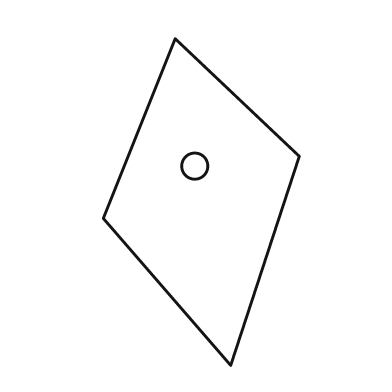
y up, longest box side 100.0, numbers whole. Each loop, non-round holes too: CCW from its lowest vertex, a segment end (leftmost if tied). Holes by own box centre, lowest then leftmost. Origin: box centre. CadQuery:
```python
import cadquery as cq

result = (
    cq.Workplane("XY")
    .moveTo(9.0, -50.0)
    .lineTo(30.0, 14.0)
    .lineTo(-8.0, 50.0)
    .lineTo(-30.0, -5.0)
    .close()
    .moveTo(-2.0, 11.0)
    .circle(4.0)
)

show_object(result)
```